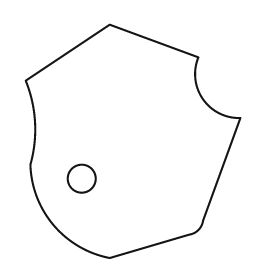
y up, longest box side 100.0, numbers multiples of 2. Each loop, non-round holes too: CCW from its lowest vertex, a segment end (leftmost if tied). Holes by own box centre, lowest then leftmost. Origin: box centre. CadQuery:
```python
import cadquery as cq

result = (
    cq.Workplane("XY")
    .moveTo(-10.0, -50.0)
    .lineTo(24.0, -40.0)
    .threePointArc((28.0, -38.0), (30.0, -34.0))
    .lineTo(46.0, 10.0)
    .threePointArc((30.0, 18.0), (28.0, 36.0))
    .lineTo(-10.0, 50.0)
    .lineTo(-46.0, 26.0)
    .threePointArc((-42.0, 8.0), (-44.0, -10.0))
    .threePointArc((-34.0, -36.0), (-10.0, -50.0))
    .close()
    .moveTo(-22.0, -16.0)
    .circle(6.0)
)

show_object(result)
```